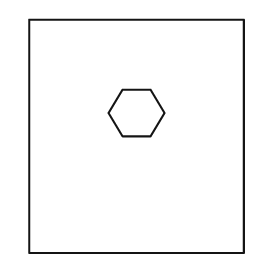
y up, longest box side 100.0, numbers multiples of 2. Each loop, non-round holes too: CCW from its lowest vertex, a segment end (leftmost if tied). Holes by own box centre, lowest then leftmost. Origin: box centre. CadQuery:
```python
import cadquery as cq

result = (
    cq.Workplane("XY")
    .moveTo(-46.0, -50.0)
    .lineTo(46.0, -50.0)
    .lineTo(46.0, 50.0)
    .lineTo(-46.0, 50.0)
    .close()
    .moveTo(-6.0, 0.0)
    .lineTo(6.0, 0.0)
    .lineTo(12.0, 10.0)
    .lineTo(6.0, 20.0)
    .lineTo(-6.0, 20.0)
    .lineTo(-12.0, 10.0)
    .close()
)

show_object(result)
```